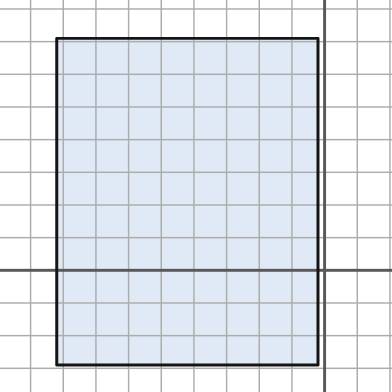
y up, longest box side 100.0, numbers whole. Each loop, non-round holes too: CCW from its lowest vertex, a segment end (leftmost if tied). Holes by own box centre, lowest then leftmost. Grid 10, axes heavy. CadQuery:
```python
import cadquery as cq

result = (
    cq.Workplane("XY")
    .moveTo(-82.0, -29.0)
    .lineTo(-2.0, -29.0)
    .lineTo(-2.0, 71.0)
    .lineTo(-82.0, 71.0)
    .close()
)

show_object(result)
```